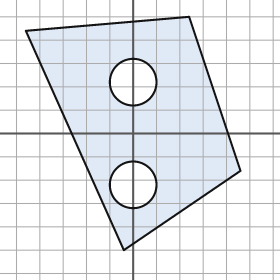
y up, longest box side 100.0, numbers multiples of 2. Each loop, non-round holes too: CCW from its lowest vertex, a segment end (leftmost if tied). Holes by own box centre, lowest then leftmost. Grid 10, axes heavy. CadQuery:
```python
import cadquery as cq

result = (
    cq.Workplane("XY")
    .moveTo(-4.0, -50.0)
    .lineTo(46.0, -16.0)
    .lineTo(24.0, 50.0)
    .lineTo(-46.0, 44.0)
    .close()
    .moveTo(0.0, -22.0)
    .circle(10.0)
    .moveTo(0.0, 22.0)
    .circle(10.0)
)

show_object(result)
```